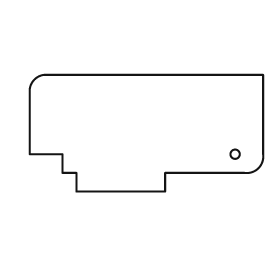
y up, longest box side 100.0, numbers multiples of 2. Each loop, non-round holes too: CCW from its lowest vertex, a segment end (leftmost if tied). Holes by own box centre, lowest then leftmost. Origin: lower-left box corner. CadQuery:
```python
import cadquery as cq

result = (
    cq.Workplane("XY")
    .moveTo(20.0, 0.0)
    .lineTo(58.0, 0.0)
    .lineTo(58.0, 8.0)
    .lineTo(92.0, 8.0)
    .threePointArc((98.0, 10.0), (100.0, 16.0))
    .lineTo(100.0, 50.0)
    .lineTo(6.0, 50.0)
    .threePointArc((2.0, 48.0), (0.0, 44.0))
    .lineTo(0.0, 16.0)
    .lineTo(14.0, 16.0)
    .lineTo(14.0, 8.0)
    .lineTo(20.0, 8.0)
    .close()
    .moveTo(88.0, 16.0)
    .circle(2.0)
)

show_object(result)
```